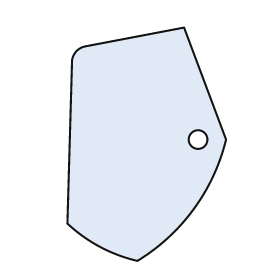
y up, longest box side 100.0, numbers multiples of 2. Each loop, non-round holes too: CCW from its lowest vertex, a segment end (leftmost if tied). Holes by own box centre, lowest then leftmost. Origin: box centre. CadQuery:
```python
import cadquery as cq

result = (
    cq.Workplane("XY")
    .moveTo(-4.0, -50.0)
    .threePointArc((20.0, -28.0), (34.0, 2.0))
    .lineTo(16.0, 50.0)
    .lineTo(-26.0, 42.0)
    .threePointArc((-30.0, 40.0), (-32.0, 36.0))
    .lineTo(-34.0, -34.0)
    .threePointArc((-20.0, -44.0), (-4.0, -50.0))
    .close()
    .moveTo(22.0, 2.0)
    .circle(4.0)
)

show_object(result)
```